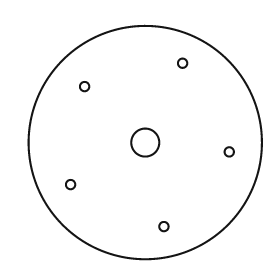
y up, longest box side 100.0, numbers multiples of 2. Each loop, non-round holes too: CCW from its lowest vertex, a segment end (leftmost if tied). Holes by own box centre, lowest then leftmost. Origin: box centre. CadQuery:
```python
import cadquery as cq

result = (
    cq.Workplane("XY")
    .moveTo(0.0, 0.0)
    .circle(50.0)
    .moveTo(8.0, -36.0)
    .circle(2.0)
    .moveTo(-32.0, -18.0)
    .circle(2.0)
    .moveTo(36.0, -4.0)
    .circle(2.0)
    .moveTo(0.0, 0.0)
    .circle(6.0)
    .moveTo(-26.0, 24.0)
    .circle(2.0)
    .moveTo(16.0, 34.0)
    .circle(2.0)
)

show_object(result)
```